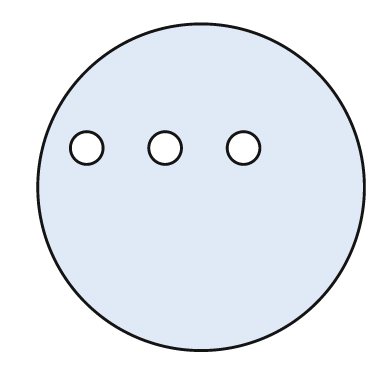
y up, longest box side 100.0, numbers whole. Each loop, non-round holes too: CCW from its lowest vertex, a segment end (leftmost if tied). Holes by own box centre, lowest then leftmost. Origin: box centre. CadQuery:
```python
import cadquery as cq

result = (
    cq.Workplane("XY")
    .moveTo(0.0, 0.0)
    .circle(50.0)
    .moveTo(-35.0, 12.0)
    .circle(5.0)
    .moveTo(-11.0, 12.0)
    .circle(5.0)
    .moveTo(13.0, 12.0)
    .circle(5.0)
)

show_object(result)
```